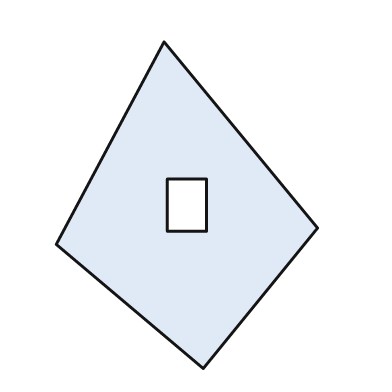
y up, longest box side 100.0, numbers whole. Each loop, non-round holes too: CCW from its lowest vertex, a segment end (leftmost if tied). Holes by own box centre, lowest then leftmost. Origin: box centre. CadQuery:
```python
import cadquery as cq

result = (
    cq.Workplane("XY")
    .moveTo(5.0, -50.0)
    .lineTo(40.0, -7.0)
    .lineTo(-7.0, 50.0)
    .lineTo(-40.0, -12.0)
    .close()
    .moveTo(-6.0, -8.0)
    .lineTo(6.0, -8.0)
    .lineTo(6.0, 8.0)
    .lineTo(-6.0, 8.0)
    .close()
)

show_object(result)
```